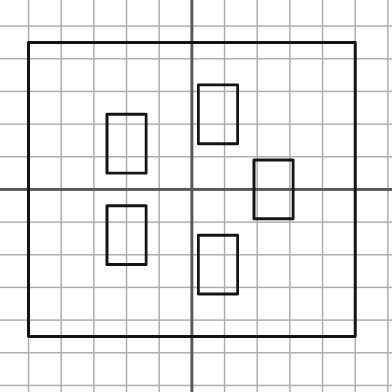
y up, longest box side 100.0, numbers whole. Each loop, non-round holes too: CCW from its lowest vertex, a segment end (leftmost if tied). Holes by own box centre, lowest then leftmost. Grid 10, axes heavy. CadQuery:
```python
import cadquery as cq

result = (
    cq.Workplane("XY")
    .moveTo(-50.0, -45.0)
    .lineTo(50.0, -45.0)
    .lineTo(50.0, 45.0)
    .lineTo(-50.0, 45.0)
    .close()
    .moveTo(2.0, -32.0)
    .lineTo(14.0, -32.0)
    .lineTo(14.0, -14.0)
    .lineTo(2.0, -14.0)
    .close()
    .moveTo(-26.0, -23.0)
    .lineTo(-14.0, -23.0)
    .lineTo(-14.0, -5.0)
    .lineTo(-26.0, -5.0)
    .close()
    .moveTo(19.0, -9.0)
    .lineTo(31.0, -9.0)
    .lineTo(31.0, 9.0)
    .lineTo(19.0, 9.0)
    .close()
    .moveTo(-26.0, 5.0)
    .lineTo(-14.0, 5.0)
    .lineTo(-14.0, 23.0)
    .lineTo(-26.0, 23.0)
    .close()
    .moveTo(2.0, 14.0)
    .lineTo(14.0, 14.0)
    .lineTo(14.0, 32.0)
    .lineTo(2.0, 32.0)
    .close()
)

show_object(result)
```